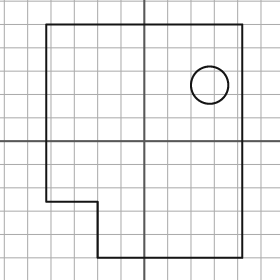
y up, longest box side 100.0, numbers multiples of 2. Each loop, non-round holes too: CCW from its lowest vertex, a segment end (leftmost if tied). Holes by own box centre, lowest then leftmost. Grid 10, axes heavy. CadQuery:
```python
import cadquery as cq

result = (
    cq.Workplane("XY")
    .moveTo(-20.0, -50.0)
    .lineTo(42.0, -50.0)
    .lineTo(42.0, 50.0)
    .lineTo(-42.0, 50.0)
    .lineTo(-42.0, -26.0)
    .lineTo(-20.0, -26.0)
    .close()
    .moveTo(28.0, 24.0)
    .circle(8.0)
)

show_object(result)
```